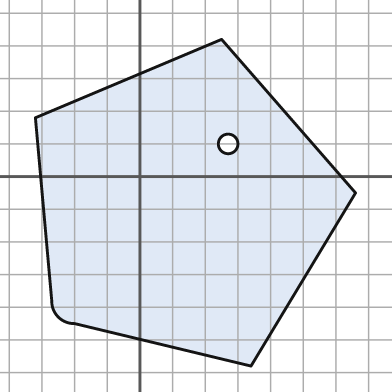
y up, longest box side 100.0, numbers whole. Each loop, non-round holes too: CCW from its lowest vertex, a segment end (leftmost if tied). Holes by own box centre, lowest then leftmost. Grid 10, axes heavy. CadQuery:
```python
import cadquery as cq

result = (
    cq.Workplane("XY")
    .moveTo(34.0, -58.0)
    .lineTo(66.0, -5.0)
    .lineTo(25.0, 42.0)
    .lineTo(-32.0, 18.0)
    .lineTo(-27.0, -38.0)
    .threePointArc((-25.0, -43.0), (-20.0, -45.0))
    .close()
    .moveTo(27.0, 10.0)
    .circle(3.0)
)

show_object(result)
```